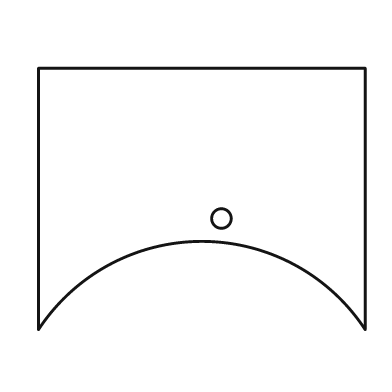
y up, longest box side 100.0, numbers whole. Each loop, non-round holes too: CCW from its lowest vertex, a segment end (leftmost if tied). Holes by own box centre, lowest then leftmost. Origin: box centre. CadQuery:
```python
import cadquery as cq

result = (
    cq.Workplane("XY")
    .moveTo(-50.0, -40.0)
    .threePointArc((0.0, -13.0), (50.0, -40.0))
    .lineTo(50.0, 40.0)
    .lineTo(-50.0, 40.0)
    .close()
    .moveTo(6.0, -6.0)
    .circle(3.0)
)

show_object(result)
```